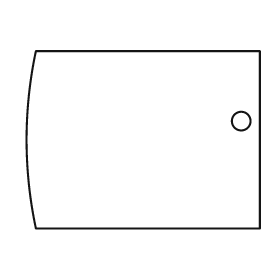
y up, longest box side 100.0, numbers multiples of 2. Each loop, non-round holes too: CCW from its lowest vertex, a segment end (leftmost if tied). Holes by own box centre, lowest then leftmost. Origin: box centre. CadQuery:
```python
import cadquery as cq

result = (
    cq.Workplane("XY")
    .moveTo(-46.0, -38.0)
    .lineTo(50.0, -38.0)
    .lineTo(50.0, 38.0)
    .lineTo(-46.0, 38.0)
    .threePointArc((-50.0, 0.0), (-46.0, -38.0))
    .close()
    .moveTo(42.0, 8.0)
    .circle(4.0)
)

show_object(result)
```